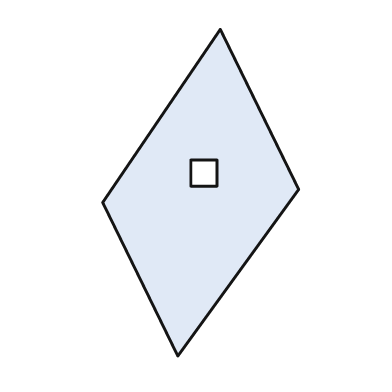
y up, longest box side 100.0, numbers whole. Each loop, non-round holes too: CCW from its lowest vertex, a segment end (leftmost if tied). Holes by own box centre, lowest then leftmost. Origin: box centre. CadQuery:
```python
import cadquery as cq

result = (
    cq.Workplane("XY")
    .moveTo(-7.0, -50.0)
    .lineTo(30.0, 1.0)
    .lineTo(6.0, 50.0)
    .lineTo(-30.0, -3.0)
    .close()
    .moveTo(-3.0, 2.0)
    .lineTo(5.0, 2.0)
    .lineTo(5.0, 10.0)
    .lineTo(-3.0, 10.0)
    .close()
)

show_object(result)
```